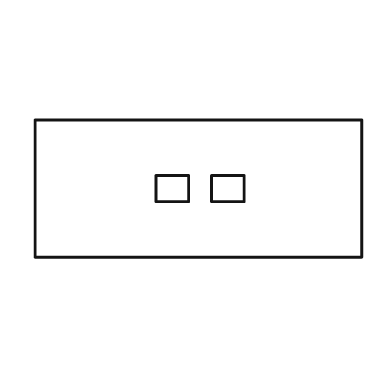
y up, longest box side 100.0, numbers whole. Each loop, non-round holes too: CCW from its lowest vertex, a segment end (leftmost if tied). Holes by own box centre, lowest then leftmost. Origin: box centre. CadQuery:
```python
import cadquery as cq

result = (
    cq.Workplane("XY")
    .moveTo(-50.0, -21.0)
    .lineTo(50.0, -21.0)
    .lineTo(50.0, 21.0)
    .lineTo(-50.0, 21.0)
    .close()
    .moveTo(-13.0, -4.0)
    .lineTo(-3.0, -4.0)
    .lineTo(-3.0, 4.0)
    .lineTo(-13.0, 4.0)
    .close()
    .moveTo(4.0, -4.0)
    .lineTo(14.0, -4.0)
    .lineTo(14.0, 4.0)
    .lineTo(4.0, 4.0)
    .close()
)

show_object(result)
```